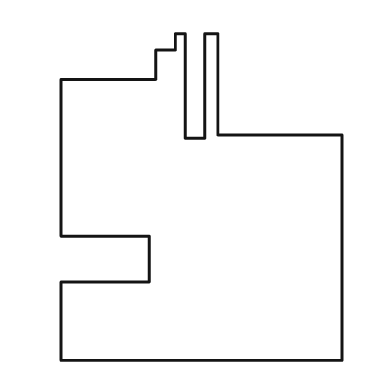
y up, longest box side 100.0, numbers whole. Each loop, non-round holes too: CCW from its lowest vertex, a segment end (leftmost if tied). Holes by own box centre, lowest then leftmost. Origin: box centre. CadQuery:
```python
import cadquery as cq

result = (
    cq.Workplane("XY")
    .moveTo(-43.0, -50.0)
    .lineTo(43.0, -50.0)
    .lineTo(43.0, 19.0)
    .lineTo(5.0, 19.0)
    .lineTo(5.0, 50.0)
    .lineTo(1.0, 50.0)
    .lineTo(1.0, 18.0)
    .lineTo(-5.0, 18.0)
    .lineTo(-5.0, 50.0)
    .lineTo(-8.0, 50.0)
    .lineTo(-8.0, 45.0)
    .lineTo(-14.0, 45.0)
    .lineTo(-14.0, 36.0)
    .lineTo(-43.0, 36.0)
    .lineTo(-43.0, -12.0)
    .lineTo(-16.0, -12.0)
    .lineTo(-16.0, -26.0)
    .lineTo(-43.0, -26.0)
    .close()
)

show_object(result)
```